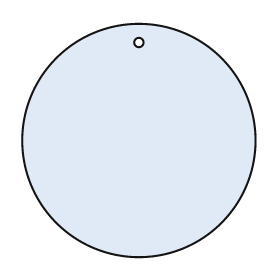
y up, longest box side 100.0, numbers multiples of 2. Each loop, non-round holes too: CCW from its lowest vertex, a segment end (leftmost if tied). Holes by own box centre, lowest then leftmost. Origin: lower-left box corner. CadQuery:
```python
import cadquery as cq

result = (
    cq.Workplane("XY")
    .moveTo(50.0, 50.0)
    .circle(50.0)
    .moveTo(50.0, 92.0)
    .circle(2.0)
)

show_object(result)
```